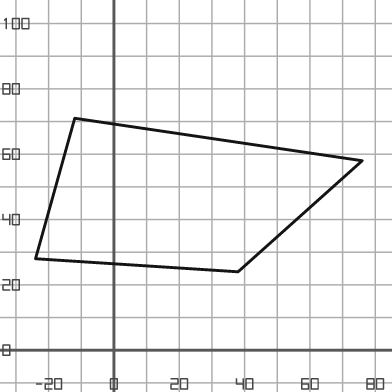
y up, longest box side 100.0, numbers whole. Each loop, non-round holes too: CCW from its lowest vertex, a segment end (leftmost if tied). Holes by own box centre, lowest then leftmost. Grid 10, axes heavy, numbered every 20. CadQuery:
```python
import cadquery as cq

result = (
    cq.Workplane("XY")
    .moveTo(38.0, 24.0)
    .lineTo(76.0, 58.0)
    .lineTo(-12.0, 71.0)
    .lineTo(-24.0, 28.0)
    .close()
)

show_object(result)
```